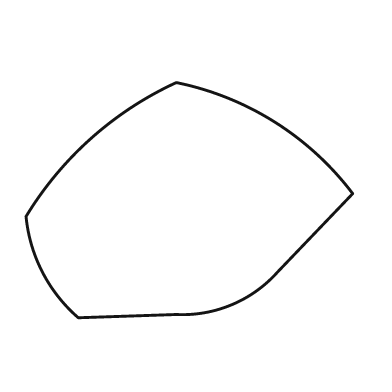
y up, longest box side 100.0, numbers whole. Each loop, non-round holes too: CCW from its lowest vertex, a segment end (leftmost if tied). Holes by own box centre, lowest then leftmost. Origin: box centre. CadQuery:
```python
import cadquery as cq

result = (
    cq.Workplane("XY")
    .moveTo(-34.0, -36.0)
    .lineTo(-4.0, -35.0)
    .threePointArc((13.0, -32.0), (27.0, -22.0))
    .lineTo(50.0, 2.0)
    .threePointArc((26.0, 24.0), (-4.0, 36.0))
    .threePointArc((-30.0, 19.0), (-50.0, -5.0))
    .threePointArc((-45.0, -22.0), (-34.0, -36.0))
    .close()
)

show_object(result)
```